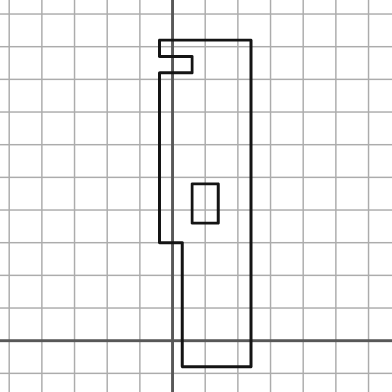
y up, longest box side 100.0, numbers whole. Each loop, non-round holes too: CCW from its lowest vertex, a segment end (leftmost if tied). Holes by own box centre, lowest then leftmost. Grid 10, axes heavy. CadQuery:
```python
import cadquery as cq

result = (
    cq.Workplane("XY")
    .moveTo(3.0, -8.0)
    .lineTo(24.0, -8.0)
    .lineTo(24.0, 92.0)
    .lineTo(-4.0, 92.0)
    .lineTo(-4.0, 87.0)
    .lineTo(6.0, 87.0)
    .lineTo(6.0, 82.0)
    .lineTo(-4.0, 82.0)
    .lineTo(-4.0, 30.0)
    .lineTo(3.0, 30.0)
    .close()
    .moveTo(6.0, 36.0)
    .lineTo(14.0, 36.0)
    .lineTo(14.0, 48.0)
    .lineTo(6.0, 48.0)
    .close()
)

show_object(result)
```